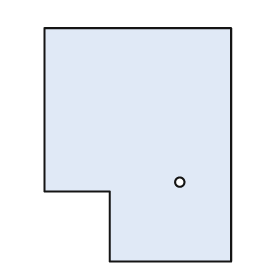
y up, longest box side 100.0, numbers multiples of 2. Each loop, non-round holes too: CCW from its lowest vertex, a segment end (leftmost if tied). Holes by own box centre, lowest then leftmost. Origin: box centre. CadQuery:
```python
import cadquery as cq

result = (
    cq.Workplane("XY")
    .moveTo(-12.0, -50.0)
    .lineTo(40.0, -50.0)
    .lineTo(40.0, 50.0)
    .lineTo(-40.0, 50.0)
    .lineTo(-40.0, -20.0)
    .lineTo(-12.0, -20.0)
    .close()
    .moveTo(18.0, -16.0)
    .circle(2.0)
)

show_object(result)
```